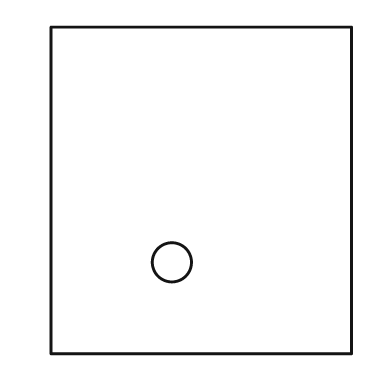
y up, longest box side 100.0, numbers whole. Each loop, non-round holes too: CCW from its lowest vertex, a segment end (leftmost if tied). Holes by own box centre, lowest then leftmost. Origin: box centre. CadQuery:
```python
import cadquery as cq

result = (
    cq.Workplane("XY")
    .moveTo(-46.0, -50.0)
    .lineTo(46.0, -50.0)
    .lineTo(46.0, 50.0)
    .lineTo(-46.0, 50.0)
    .close()
    .moveTo(-9.0, -22.0)
    .circle(6.0)
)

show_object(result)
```